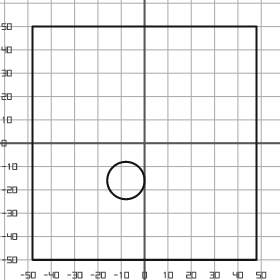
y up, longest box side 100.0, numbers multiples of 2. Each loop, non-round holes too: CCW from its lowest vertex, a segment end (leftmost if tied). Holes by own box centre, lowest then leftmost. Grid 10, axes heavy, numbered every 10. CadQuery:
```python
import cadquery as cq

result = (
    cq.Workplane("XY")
    .moveTo(-48.0, -50.0)
    .lineTo(48.0, -50.0)
    .lineTo(48.0, 50.0)
    .lineTo(-48.0, 50.0)
    .close()
    .moveTo(-8.0, -16.0)
    .circle(8.0)
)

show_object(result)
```